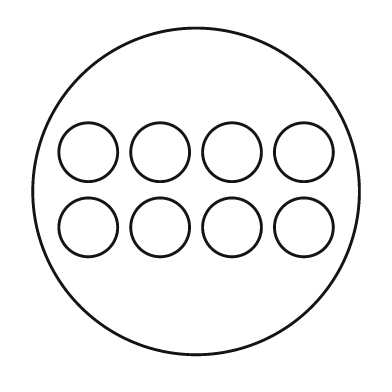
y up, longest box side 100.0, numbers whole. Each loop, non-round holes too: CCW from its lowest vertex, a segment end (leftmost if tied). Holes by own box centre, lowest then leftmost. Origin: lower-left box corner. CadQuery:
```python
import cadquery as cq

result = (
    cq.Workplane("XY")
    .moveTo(50.0, 50.0)
    .circle(50.0)
    .moveTo(17.0, 39.0)
    .circle(9.0)
    .moveTo(39.0, 39.0)
    .circle(9.0)
    .moveTo(61.0, 39.0)
    .circle(9.0)
    .moveTo(83.0, 39.0)
    .circle(9.0)
    .moveTo(17.0, 62.0)
    .circle(9.0)
    .moveTo(39.0, 62.0)
    .circle(9.0)
    .moveTo(61.0, 62.0)
    .circle(9.0)
    .moveTo(83.0, 62.0)
    .circle(9.0)
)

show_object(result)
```